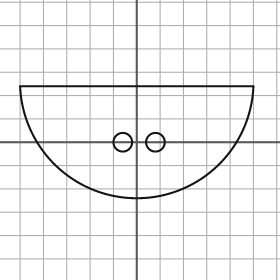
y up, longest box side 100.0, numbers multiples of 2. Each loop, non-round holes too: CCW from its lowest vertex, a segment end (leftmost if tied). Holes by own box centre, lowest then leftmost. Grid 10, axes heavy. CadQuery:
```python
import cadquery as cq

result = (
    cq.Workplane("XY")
    .moveTo(-50.0, 24.0)
    .threePointArc((0.0, -24.0), (50.0, 24.0))
    .close()
    .moveTo(-6.0, 0.0)
    .circle(4.0)
    .moveTo(8.0, 0.0)
    .circle(4.0)
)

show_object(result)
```